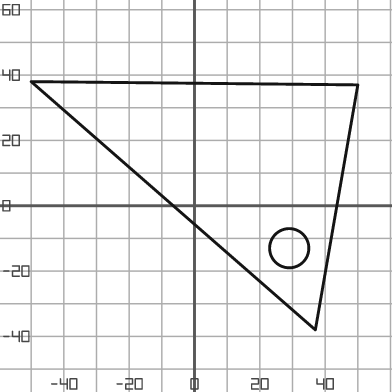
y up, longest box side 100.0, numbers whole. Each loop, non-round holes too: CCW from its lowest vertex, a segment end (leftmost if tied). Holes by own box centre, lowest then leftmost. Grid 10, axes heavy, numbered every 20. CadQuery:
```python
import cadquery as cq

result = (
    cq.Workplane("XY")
    .moveTo(37.0, -38.0)
    .lineTo(50.0, 37.0)
    .lineTo(-50.0, 38.0)
    .close()
    .moveTo(29.0, -13.0)
    .circle(6.0)
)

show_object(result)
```